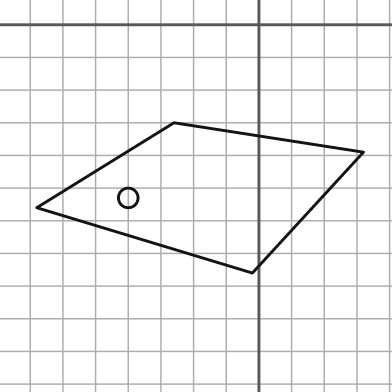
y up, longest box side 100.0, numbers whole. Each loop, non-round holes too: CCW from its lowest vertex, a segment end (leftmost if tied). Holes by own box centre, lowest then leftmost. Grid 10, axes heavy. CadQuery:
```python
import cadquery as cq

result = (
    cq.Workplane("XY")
    .moveTo(-2.0, -76.0)
    .lineTo(32.0, -39.0)
    .lineTo(-26.0, -30.0)
    .lineTo(-68.0, -56.0)
    .close()
    .moveTo(-40.0, -53.0)
    .circle(3.0)
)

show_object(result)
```